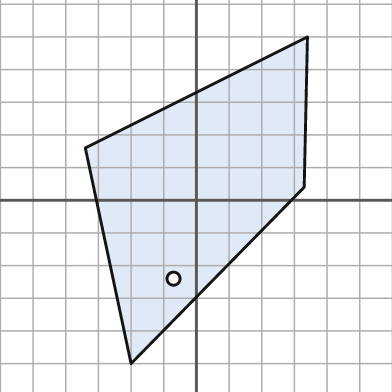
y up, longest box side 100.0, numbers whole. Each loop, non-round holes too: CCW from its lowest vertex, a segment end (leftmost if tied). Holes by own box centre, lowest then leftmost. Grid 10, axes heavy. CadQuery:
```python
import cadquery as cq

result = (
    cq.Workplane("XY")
    .moveTo(-20.0, -50.0)
    .lineTo(33.0, 4.0)
    .lineTo(34.0, 50.0)
    .lineTo(-34.0, 16.0)
    .close()
    .moveTo(-7.0, -24.0)
    .circle(2.0)
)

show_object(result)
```